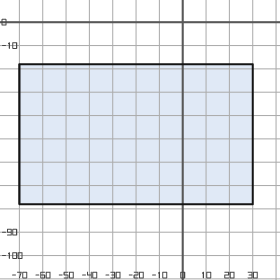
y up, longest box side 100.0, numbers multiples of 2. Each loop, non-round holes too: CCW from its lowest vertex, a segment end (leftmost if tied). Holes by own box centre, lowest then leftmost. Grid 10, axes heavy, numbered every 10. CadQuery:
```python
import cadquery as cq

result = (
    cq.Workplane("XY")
    .moveTo(-70.0, -78.0)
    .lineTo(30.0, -78.0)
    .lineTo(30.0, -18.0)
    .lineTo(-70.0, -18.0)
    .close()
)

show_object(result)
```